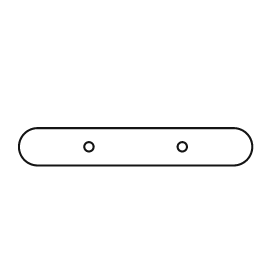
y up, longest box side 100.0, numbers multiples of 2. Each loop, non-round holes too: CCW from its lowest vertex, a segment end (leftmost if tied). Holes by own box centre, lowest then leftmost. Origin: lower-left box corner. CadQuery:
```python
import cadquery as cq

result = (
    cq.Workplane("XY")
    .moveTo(8.0, 0.0)
    .lineTo(92.0, 0.0)
    .threePointArc((100.0, 8.0), (92.0, 16.0))
    .lineTo(8.0, 16.0)
    .threePointArc((0.0, 8.0), (8.0, 0.0))
    .close()
    .moveTo(30.0, 8.0)
    .circle(2.0)
    .moveTo(70.0, 8.0)
    .circle(2.0)
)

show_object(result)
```